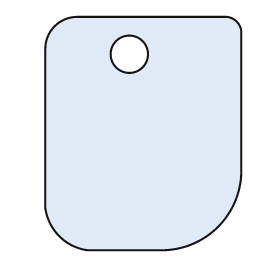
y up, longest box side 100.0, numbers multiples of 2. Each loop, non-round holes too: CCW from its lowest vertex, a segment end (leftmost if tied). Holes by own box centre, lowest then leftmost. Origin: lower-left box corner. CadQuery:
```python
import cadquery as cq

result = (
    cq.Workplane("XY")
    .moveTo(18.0, 0.0)
    .lineTo(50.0, 0.0)
    .threePointArc((74.0, 10.0), (84.0, 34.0))
    .lineTo(84.0, 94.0)
    .threePointArc((82.0, 98.0), (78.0, 100.0))
    .lineTo(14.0, 100.0)
    .threePointArc((4.0, 96.0), (0.0, 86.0))
    .lineTo(0.0, 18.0)
    .threePointArc((6.0, 6.0), (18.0, 0.0))
    .close()
    .moveTo(36.0, 84.0)
    .circle(8.0)
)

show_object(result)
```